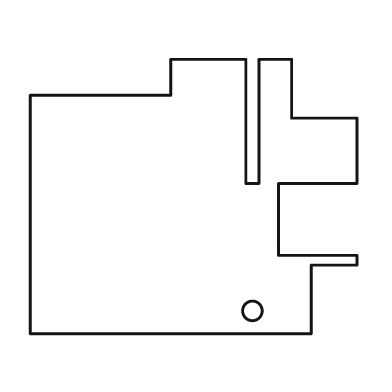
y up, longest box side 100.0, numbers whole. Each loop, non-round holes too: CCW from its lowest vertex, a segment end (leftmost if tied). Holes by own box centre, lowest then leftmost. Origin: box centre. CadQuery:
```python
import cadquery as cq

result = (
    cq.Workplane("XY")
    .moveTo(-50.0, -42.0)
    .lineTo(36.0, -42.0)
    .lineTo(36.0, -21.0)
    .lineTo(50.0, -21.0)
    .lineTo(50.0, -18.0)
    .lineTo(26.0, -18.0)
    .lineTo(26.0, 4.0)
    .lineTo(50.0, 4.0)
    .lineTo(50.0, 24.0)
    .lineTo(30.0, 24.0)
    .lineTo(30.0, 42.0)
    .lineTo(20.0, 42.0)
    .lineTo(20.0, 4.0)
    .lineTo(16.0, 4.0)
    .lineTo(16.0, 42.0)
    .lineTo(-7.0, 42.0)
    .lineTo(-7.0, 31.0)
    .lineTo(-50.0, 31.0)
    .close()
    .moveTo(18.0, -35.0)
    .circle(3.0)
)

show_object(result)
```